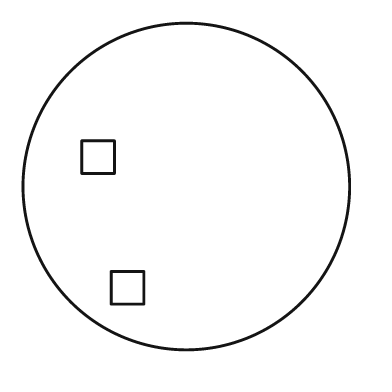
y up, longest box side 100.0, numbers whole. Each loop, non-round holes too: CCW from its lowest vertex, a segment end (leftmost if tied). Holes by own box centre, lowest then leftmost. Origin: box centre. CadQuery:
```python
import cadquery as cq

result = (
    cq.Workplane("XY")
    .moveTo(0.0, 0.0)
    .circle(50.0)
    .moveTo(-23.0, -36.0)
    .lineTo(-13.0, -36.0)
    .lineTo(-13.0, -26.0)
    .lineTo(-23.0, -26.0)
    .close()
    .moveTo(-32.0, 4.0)
    .lineTo(-22.0, 4.0)
    .lineTo(-22.0, 14.0)
    .lineTo(-32.0, 14.0)
    .close()
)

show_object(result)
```